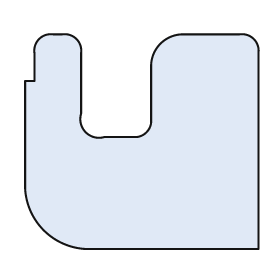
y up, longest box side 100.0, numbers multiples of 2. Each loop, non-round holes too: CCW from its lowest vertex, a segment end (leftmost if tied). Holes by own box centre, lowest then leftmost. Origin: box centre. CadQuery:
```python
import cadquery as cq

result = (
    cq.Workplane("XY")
    .moveTo(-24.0, -46.0)
    .lineTo(50.0, -46.0)
    .lineTo(50.0, 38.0)
    .threePointArc((48.0, 44.0), (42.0, 46.0))
    .lineTo(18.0, 46.0)
    .threePointArc((8.0, 42.0), (4.0, 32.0))
    .lineTo(4.0, 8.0)
    .threePointArc((2.0, 4.0), (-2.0, 2.0))
    .lineTo(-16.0, 2.0)
    .threePointArc((-24.0, 4.0), (-26.0, 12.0))
    .lineTo(-26.0, 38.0)
    .threePointArc((-28.0, 44.0), (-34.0, 46.0))
    .lineTo(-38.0, 46.0)
    .threePointArc((-44.0, 44.0), (-46.0, 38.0))
    .lineTo(-46.0, 26.0)
    .lineTo(-50.0, 26.0)
    .lineTo(-50.0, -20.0)
    .threePointArc((-42.0, -38.0), (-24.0, -46.0))
    .close()
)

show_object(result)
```